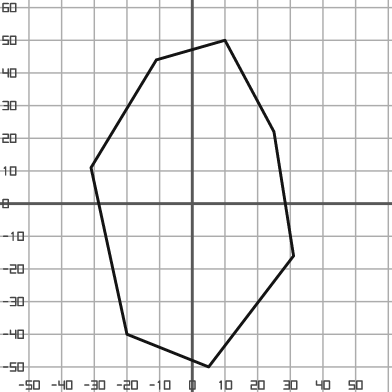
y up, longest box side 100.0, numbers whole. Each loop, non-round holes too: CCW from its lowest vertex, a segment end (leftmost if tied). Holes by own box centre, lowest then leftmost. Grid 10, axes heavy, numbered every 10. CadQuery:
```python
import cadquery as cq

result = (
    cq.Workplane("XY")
    .moveTo(5.0, -50.0)
    .lineTo(31.0, -16.0)
    .lineTo(25.0, 22.0)
    .lineTo(10.0, 50.0)
    .lineTo(-11.0, 44.0)
    .lineTo(-31.0, 11.0)
    .lineTo(-20.0, -40.0)
    .close()
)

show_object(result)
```